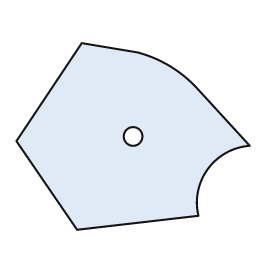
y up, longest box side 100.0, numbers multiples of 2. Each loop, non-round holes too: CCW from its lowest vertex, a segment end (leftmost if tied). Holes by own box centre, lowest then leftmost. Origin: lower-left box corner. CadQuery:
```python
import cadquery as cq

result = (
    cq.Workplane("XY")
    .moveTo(26.0, 0.0)
    .lineTo(78.0, 6.0)
    .threePointArc((82.0, 26.0), (100.0, 36.0))
    .lineTo(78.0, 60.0)
    .threePointArc((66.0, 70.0), (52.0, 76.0))
    .lineTo(28.0, 80.0)
    .lineTo(0.0, 38.0)
    .close()
    .moveTo(50.0, 40.0)
    .circle(4.0)
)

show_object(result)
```